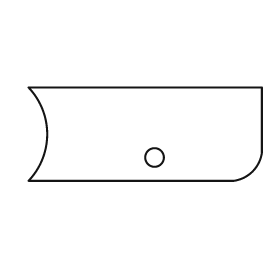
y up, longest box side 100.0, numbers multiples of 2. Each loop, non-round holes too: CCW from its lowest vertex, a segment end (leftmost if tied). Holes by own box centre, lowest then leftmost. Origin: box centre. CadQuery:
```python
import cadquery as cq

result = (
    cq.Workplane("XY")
    .moveTo(-50.0, -20.0)
    .lineTo(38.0, -20.0)
    .threePointArc((46.0, -16.0), (50.0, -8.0))
    .lineTo(50.0, 20.0)
    .lineTo(-50.0, 20.0)
    .threePointArc((-42.0, 0.0), (-50.0, -20.0))
    .close()
    .moveTo(4.0, -10.0)
    .circle(4.0)
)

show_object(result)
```